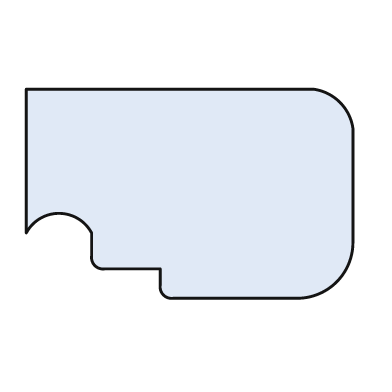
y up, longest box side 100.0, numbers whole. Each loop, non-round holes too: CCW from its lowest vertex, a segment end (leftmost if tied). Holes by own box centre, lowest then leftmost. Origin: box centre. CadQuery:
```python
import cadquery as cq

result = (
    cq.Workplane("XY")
    .moveTo(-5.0, -32.0)
    .lineTo(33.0, -32.0)
    .threePointArc((45.0, -27.0), (50.0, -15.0))
    .lineTo(50.0, 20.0)
    .threePointArc((46.0, 28.0), (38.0, 32.0))
    .lineTo(-50.0, 32.0)
    .lineTo(-50.0, -12.0)
    .threePointArc((-40.0, -6.0), (-30.0, -12.0))
    .lineTo(-30.0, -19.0)
    .threePointArc((-29.0, -22.0), (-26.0, -23.0))
    .lineTo(-9.0, -23.0)
    .lineTo(-9.0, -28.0)
    .threePointArc((-8.0, -31.0), (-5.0, -32.0))
    .close()
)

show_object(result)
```